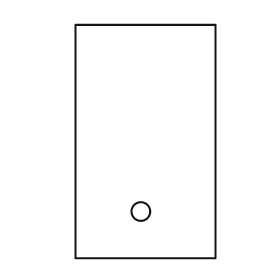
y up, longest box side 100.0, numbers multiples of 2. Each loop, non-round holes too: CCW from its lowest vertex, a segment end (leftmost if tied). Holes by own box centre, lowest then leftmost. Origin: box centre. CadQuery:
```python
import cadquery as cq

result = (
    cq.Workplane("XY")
    .moveTo(-30.0, -50.0)
    .lineTo(30.0, -50.0)
    .lineTo(30.0, 50.0)
    .lineTo(-30.0, 50.0)
    .close()
    .moveTo(-2.0, -30.0)
    .circle(4.0)
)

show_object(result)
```